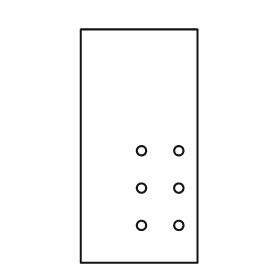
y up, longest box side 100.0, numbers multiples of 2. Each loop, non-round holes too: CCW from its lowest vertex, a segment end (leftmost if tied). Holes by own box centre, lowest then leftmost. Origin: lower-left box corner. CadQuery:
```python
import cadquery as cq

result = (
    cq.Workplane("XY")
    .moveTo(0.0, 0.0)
    .lineTo(50.0, 0.0)
    .lineTo(50.0, 100.0)
    .lineTo(0.0, 100.0)
    .close()
    .moveTo(26.0, 16.0)
    .circle(2.0)
    .moveTo(42.0, 16.0)
    .circle(2.0)
    .moveTo(26.0, 32.0)
    .circle(2.0)
    .moveTo(42.0, 32.0)
    .circle(2.0)
    .moveTo(26.0, 48.0)
    .circle(2.0)
    .moveTo(42.0, 48.0)
    .circle(2.0)
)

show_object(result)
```